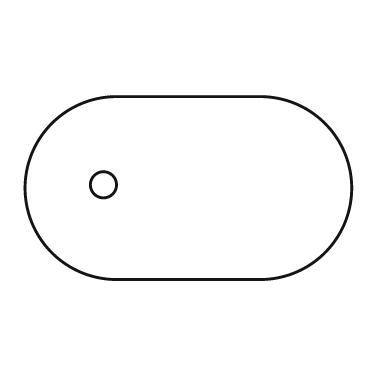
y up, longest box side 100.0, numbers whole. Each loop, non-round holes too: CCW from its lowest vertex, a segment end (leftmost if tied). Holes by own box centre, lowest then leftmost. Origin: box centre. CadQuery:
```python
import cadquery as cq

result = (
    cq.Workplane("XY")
    .moveTo(-22.0, -28.0)
    .lineTo(22.0, -28.0)
    .threePointArc((50.0, 0.0), (22.0, 28.0))
    .lineTo(-22.0, 28.0)
    .threePointArc((-50.0, 0.0), (-22.0, -28.0))
    .close()
    .moveTo(-26.0, 1.0)
    .circle(4.0)
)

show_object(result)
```